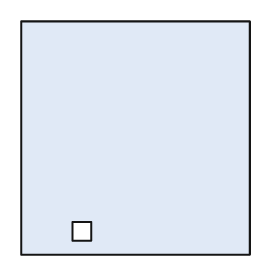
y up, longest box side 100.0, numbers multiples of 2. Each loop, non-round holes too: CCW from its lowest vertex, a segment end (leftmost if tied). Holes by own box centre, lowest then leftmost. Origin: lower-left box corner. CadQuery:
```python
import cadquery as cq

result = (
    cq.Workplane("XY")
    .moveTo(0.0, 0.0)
    .lineTo(98.0, 0.0)
    .lineTo(98.0, 100.0)
    .lineTo(0.0, 100.0)
    .close()
    .moveTo(22.0, 6.0)
    .lineTo(30.0, 6.0)
    .lineTo(30.0, 14.0)
    .lineTo(22.0, 14.0)
    .close()
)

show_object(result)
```